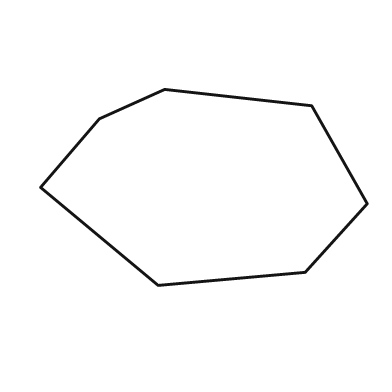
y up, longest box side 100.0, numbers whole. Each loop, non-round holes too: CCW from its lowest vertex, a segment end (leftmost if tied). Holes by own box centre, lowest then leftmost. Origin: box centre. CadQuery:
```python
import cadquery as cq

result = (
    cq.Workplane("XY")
    .moveTo(-14.0, -30.0)
    .lineTo(31.0, -26.0)
    .lineTo(50.0, -5.0)
    .lineTo(33.0, 25.0)
    .lineTo(-12.0, 30.0)
    .lineTo(-32.0, 21.0)
    .lineTo(-50.0, 0.0)
    .close()
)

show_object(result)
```